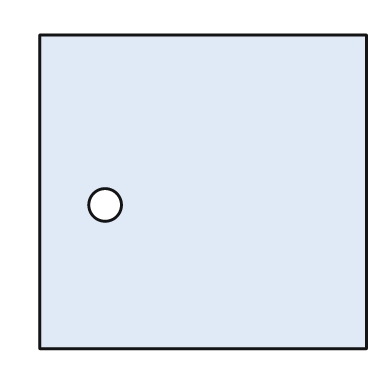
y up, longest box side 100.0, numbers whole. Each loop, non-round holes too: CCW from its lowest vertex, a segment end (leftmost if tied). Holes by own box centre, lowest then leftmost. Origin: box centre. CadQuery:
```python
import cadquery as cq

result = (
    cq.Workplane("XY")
    .moveTo(-50.0, -48.0)
    .lineTo(50.0, -48.0)
    .lineTo(50.0, 48.0)
    .lineTo(-50.0, 48.0)
    .close()
    .moveTo(-30.0, -4.0)
    .circle(5.0)
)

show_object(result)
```